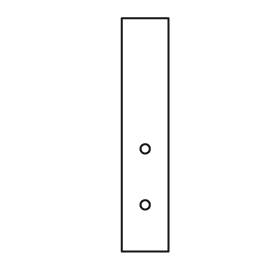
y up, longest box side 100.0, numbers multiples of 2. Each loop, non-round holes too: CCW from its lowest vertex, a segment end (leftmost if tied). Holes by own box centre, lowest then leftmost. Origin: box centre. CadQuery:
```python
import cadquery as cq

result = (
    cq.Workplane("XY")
    .moveTo(-10.0, -50.0)
    .lineTo(10.0, -50.0)
    .lineTo(10.0, 50.0)
    .lineTo(-10.0, 50.0)
    .close()
    .moveTo(0.0, -30.0)
    .circle(2.0)
    .moveTo(0.0, -6.0)
    .circle(2.0)
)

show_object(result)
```